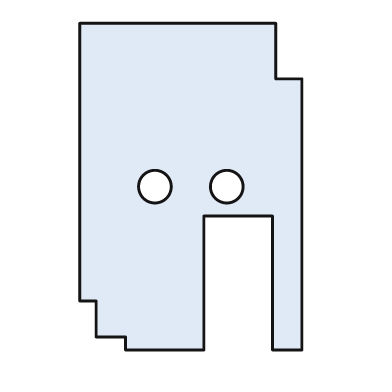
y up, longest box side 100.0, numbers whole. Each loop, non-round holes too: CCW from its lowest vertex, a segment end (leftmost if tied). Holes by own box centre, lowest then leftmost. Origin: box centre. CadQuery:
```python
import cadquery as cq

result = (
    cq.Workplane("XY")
    .moveTo(-20.0, -50.0)
    .lineTo(4.0, -50.0)
    .lineTo(4.0, -9.0)
    .lineTo(25.0, -9.0)
    .lineTo(25.0, -50.0)
    .lineTo(34.0, -50.0)
    .lineTo(34.0, 33.0)
    .lineTo(26.0, 33.0)
    .lineTo(26.0, 50.0)
    .lineTo(-34.0, 50.0)
    .lineTo(-34.0, -35.0)
    .lineTo(-29.0, -35.0)
    .lineTo(-29.0, -46.0)
    .lineTo(-20.0, -46.0)
    .close()
    .moveTo(-11.0, 0.0)
    .circle(5.0)
    .moveTo(11.0, 0.0)
    .circle(5.0)
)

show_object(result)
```